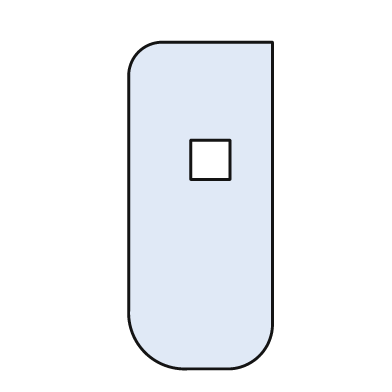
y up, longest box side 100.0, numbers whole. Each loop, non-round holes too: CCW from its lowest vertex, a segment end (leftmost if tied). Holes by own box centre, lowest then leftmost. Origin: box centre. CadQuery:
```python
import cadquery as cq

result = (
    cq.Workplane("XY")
    .moveTo(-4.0, -50.0)
    .lineTo(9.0, -50.0)
    .threePointArc((18.0, -46.0), (22.0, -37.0))
    .lineTo(22.0, 50.0)
    .lineTo(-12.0, 50.0)
    .threePointArc((-19.0, 47.0), (-22.0, 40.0))
    .lineTo(-22.0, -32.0)
    .threePointArc((-17.0, -45.0), (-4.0, -50.0))
    .close()
    .moveTo(-3.0, 8.0)
    .lineTo(9.0, 8.0)
    .lineTo(9.0, 20.0)
    .lineTo(-3.0, 20.0)
    .close()
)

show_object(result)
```